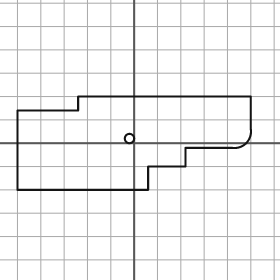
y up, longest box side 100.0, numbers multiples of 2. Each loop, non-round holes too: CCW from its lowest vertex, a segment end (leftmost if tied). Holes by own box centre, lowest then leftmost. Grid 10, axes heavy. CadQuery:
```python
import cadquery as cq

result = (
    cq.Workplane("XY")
    .moveTo(-50.0, -20.0)
    .lineTo(6.0, -20.0)
    .lineTo(6.0, -10.0)
    .lineTo(22.0, -10.0)
    .lineTo(22.0, -2.0)
    .lineTo(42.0, -2.0)
    .threePointArc((48.0, 0.0), (50.0, 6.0))
    .lineTo(50.0, 20.0)
    .lineTo(-24.0, 20.0)
    .lineTo(-24.0, 14.0)
    .lineTo(-50.0, 14.0)
    .close()
    .moveTo(-2.0, 2.0)
    .circle(2.0)
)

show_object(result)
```